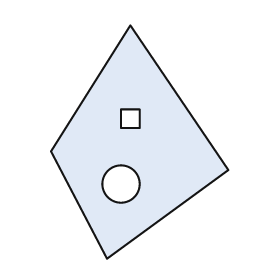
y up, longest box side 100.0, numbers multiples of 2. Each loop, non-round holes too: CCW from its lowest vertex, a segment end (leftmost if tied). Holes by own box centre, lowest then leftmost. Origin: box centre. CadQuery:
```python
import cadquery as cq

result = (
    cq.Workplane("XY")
    .moveTo(-14.0, -50.0)
    .lineTo(38.0, -12.0)
    .lineTo(-4.0, 50.0)
    .lineTo(-38.0, -4.0)
    .close()
    .moveTo(-8.0, -18.0)
    .circle(8.0)
    .moveTo(-8.0, 6.0)
    .lineTo(0.0, 6.0)
    .lineTo(0.0, 14.0)
    .lineTo(-8.0, 14.0)
    .close()
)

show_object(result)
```